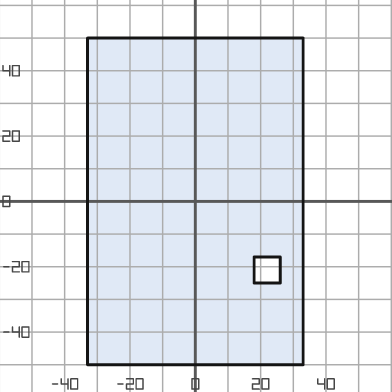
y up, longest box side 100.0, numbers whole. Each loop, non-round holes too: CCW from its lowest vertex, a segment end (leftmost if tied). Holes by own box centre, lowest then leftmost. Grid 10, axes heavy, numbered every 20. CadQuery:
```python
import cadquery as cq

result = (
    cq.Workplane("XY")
    .moveTo(-33.0, -50.0)
    .lineTo(33.0, -50.0)
    .lineTo(33.0, 50.0)
    .lineTo(-33.0, 50.0)
    .close()
    .moveTo(18.0, -25.0)
    .lineTo(26.0, -25.0)
    .lineTo(26.0, -17.0)
    .lineTo(18.0, -17.0)
    .close()
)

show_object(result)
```